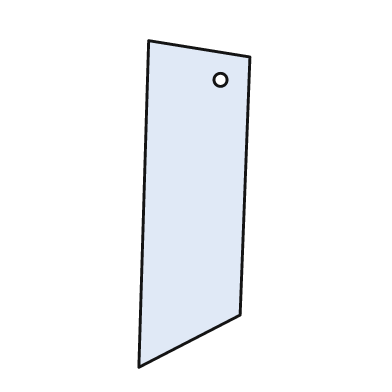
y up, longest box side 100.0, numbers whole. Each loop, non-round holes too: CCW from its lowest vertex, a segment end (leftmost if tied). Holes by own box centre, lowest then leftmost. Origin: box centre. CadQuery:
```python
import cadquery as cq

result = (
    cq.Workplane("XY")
    .moveTo(-17.0, -50.0)
    .lineTo(14.0, -34.0)
    .lineTo(17.0, 45.0)
    .lineTo(-14.0, 50.0)
    .close()
    .moveTo(8.0, 38.0)
    .circle(2.0)
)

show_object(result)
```